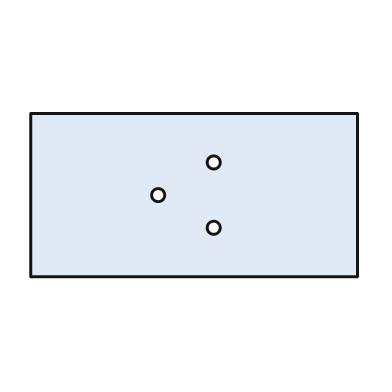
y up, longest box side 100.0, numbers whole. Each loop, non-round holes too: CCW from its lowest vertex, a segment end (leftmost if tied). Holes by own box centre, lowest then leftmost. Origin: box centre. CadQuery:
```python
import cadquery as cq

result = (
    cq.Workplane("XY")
    .moveTo(-50.0, -25.0)
    .lineTo(50.0, -25.0)
    .lineTo(50.0, 25.0)
    .lineTo(-50.0, 25.0)
    .close()
    .moveTo(6.0, -10.0)
    .circle(2.0)
    .moveTo(-11.0, 0.0)
    .circle(2.0)
    .moveTo(6.0, 10.0)
    .circle(2.0)
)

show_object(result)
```